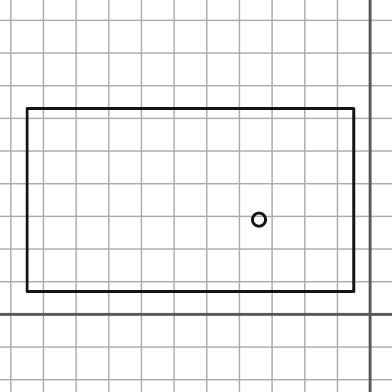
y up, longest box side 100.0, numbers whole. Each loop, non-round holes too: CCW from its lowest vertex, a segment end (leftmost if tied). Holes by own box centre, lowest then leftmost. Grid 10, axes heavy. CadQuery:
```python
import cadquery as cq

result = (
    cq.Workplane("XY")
    .moveTo(-105.0, 7.0)
    .lineTo(-5.0, 7.0)
    .lineTo(-5.0, 63.0)
    .lineTo(-105.0, 63.0)
    .close()
    .moveTo(-34.0, 29.0)
    .circle(2.0)
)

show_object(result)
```